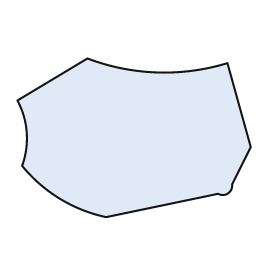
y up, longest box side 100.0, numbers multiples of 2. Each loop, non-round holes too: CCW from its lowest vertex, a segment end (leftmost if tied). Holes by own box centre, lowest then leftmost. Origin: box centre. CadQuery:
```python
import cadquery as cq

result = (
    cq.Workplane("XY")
    .moveTo(-12.0, -34.0)
    .lineTo(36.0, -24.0)
    .threePointArc((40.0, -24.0), (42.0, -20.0))
    .lineTo(50.0, -4.0)
    .lineTo(40.0, 32.0)
    .threePointArc((10.0, 28.0), (-20.0, 34.0))
    .lineTo(-50.0, 16.0)
    .threePointArc((-46.0, 2.0), (-48.0, -12.0))
    .threePointArc((-32.0, -26.0), (-12.0, -34.0))
    .close()
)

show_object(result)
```